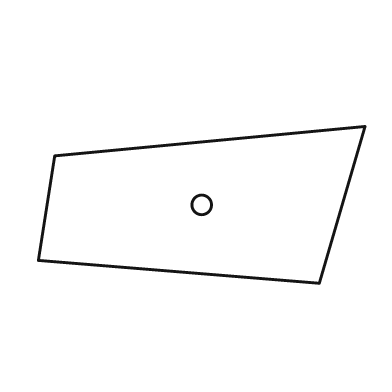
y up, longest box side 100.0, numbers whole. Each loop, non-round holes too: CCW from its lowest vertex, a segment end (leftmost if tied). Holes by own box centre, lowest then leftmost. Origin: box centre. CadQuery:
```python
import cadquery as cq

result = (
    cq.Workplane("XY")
    .moveTo(36.0, -24.0)
    .lineTo(50.0, 24.0)
    .lineTo(-45.0, 15.0)
    .lineTo(-50.0, -17.0)
    .close()
    .moveTo(0.0, 0.0)
    .circle(3.0)
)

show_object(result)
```